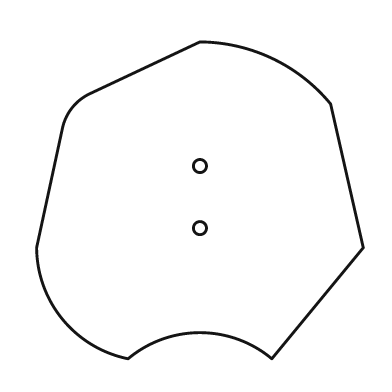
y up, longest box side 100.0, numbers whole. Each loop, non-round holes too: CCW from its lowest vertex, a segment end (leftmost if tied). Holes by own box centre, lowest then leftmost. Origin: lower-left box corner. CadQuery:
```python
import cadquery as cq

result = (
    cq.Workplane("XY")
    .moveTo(28.0, 0.0)
    .threePointArc((50.0, 8.0), (72.0, 0.0))
    .lineTo(100.0, 34.0)
    .lineTo(90.0, 78.0)
    .threePointArc((72.0, 92.0), (50.0, 97.0))
    .lineTo(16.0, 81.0)
    .threePointArc((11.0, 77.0), (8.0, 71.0))
    .lineTo(0.0, 34.0)
    .threePointArc((8.0, 12.0), (28.0, 0.0))
    .close()
    .moveTo(50.0, 40.0)
    .circle(2.0)
    .moveTo(50.0, 59.0)
    .circle(2.0)
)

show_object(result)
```